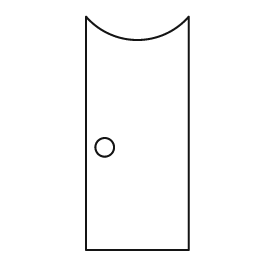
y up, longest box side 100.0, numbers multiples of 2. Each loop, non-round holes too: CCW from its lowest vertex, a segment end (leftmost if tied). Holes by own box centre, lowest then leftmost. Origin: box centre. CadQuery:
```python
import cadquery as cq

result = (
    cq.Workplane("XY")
    .moveTo(-22.0, -50.0)
    .lineTo(22.0, -50.0)
    .lineTo(22.0, 50.0)
    .threePointArc((0.0, 40.0), (-22.0, 50.0))
    .close()
    .moveTo(-14.0, -6.0)
    .circle(4.0)
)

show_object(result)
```